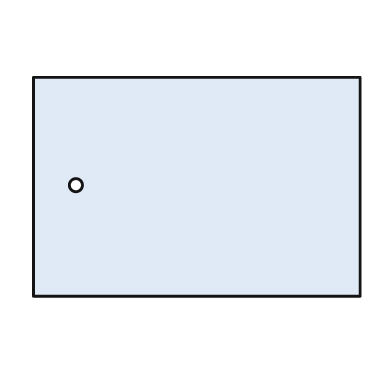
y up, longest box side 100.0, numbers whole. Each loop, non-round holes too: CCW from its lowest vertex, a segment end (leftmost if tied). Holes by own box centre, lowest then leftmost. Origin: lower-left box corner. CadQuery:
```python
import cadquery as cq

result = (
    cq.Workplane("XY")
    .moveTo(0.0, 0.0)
    .lineTo(100.0, 0.0)
    .lineTo(100.0, 67.0)
    .lineTo(0.0, 67.0)
    .close()
    .moveTo(13.0, 34.0)
    .circle(2.0)
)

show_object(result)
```